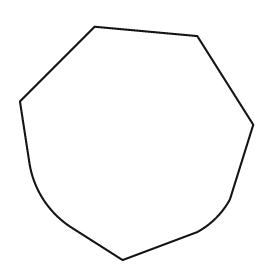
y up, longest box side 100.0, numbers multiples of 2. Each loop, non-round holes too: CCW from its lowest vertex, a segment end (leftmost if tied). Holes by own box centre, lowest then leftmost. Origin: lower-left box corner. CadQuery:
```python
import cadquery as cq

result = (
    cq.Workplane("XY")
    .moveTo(44.0, 0.0)
    .lineTo(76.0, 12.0)
    .threePointArc((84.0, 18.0), (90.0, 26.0))
    .lineTo(100.0, 58.0)
    .lineTo(76.0, 96.0)
    .lineTo(32.0, 100.0)
    .lineTo(0.0, 68.0)
    .lineTo(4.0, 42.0)
    .threePointArc((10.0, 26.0), (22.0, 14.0))
    .close()
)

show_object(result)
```